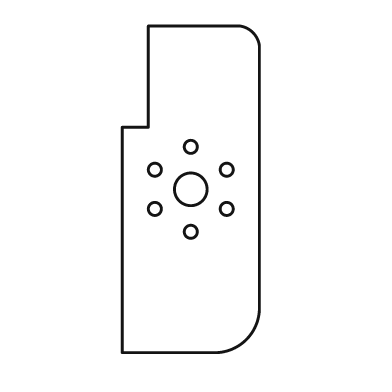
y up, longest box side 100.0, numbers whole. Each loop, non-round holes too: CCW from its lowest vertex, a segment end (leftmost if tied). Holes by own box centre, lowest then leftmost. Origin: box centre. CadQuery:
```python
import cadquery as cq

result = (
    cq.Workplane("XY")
    .moveTo(-21.0, -50.0)
    .lineTo(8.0, -50.0)
    .threePointArc((17.0, -46.0), (21.0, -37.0))
    .lineTo(21.0, 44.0)
    .threePointArc((19.0, 48.0), (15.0, 50.0))
    .lineTo(-13.0, 50.0)
    .lineTo(-13.0, 19.0)
    .lineTo(-21.0, 19.0)
    .close()
    .moveTo(0.0, -13.0)
    .circle(2.0)
    .moveTo(-11.0, -6.0)
    .circle(2.0)
    .moveTo(11.0, -6.0)
    .circle(2.0)
    .moveTo(0.0, 0.0)
    .circle(5.0)
    .moveTo(-11.0, 6.0)
    .circle(2.0)
    .moveTo(11.0, 6.0)
    .circle(2.0)
    .moveTo(0.0, 13.0)
    .circle(2.0)
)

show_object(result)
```